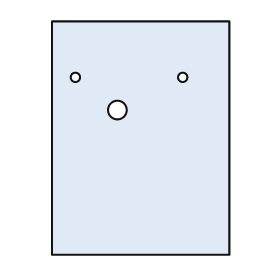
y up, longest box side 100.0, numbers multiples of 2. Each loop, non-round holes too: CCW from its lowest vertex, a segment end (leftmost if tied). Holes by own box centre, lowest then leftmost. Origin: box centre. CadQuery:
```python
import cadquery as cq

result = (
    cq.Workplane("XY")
    .moveTo(-38.0, -50.0)
    .lineTo(38.0, -50.0)
    .lineTo(38.0, 50.0)
    .lineTo(-38.0, 50.0)
    .close()
    .moveTo(-10.0, 12.0)
    .circle(4.0)
    .moveTo(-28.0, 26.0)
    .circle(2.0)
    .moveTo(18.0, 26.0)
    .circle(2.0)
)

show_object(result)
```